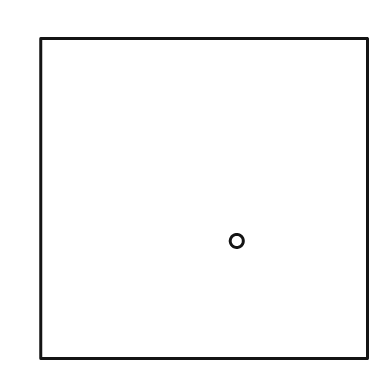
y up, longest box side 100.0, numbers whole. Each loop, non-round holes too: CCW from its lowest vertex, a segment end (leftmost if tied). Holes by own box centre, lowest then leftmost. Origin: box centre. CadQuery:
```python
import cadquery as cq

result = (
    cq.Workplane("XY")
    .moveTo(-50.0, -49.0)
    .lineTo(50.0, -49.0)
    .lineTo(50.0, 49.0)
    .lineTo(-50.0, 49.0)
    .close()
    .moveTo(10.0, -13.0)
    .circle(2.0)
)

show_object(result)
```